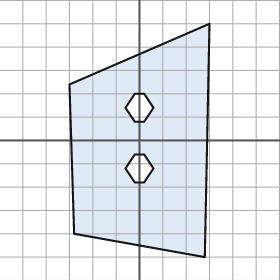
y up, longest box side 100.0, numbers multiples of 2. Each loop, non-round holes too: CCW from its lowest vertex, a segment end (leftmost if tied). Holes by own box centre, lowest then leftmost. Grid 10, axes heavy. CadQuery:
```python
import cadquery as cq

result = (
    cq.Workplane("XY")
    .moveTo(28.0, -50.0)
    .lineTo(30.0, 50.0)
    .lineTo(-30.0, 24.0)
    .lineTo(-28.0, -40.0)
    .close()
    .moveTo(-2.0, -18.0)
    .lineTo(2.0, -18.0)
    .lineTo(6.0, -12.0)
    .lineTo(2.0, -6.0)
    .lineTo(-2.0, -6.0)
    .lineTo(-6.0, -12.0)
    .close()
    .moveTo(-2.0, 8.0)
    .lineTo(2.0, 8.0)
    .lineTo(6.0, 14.0)
    .lineTo(2.0, 20.0)
    .lineTo(-2.0, 20.0)
    .lineTo(-6.0, 14.0)
    .close()
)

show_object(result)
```